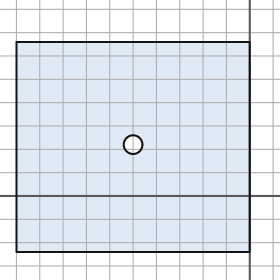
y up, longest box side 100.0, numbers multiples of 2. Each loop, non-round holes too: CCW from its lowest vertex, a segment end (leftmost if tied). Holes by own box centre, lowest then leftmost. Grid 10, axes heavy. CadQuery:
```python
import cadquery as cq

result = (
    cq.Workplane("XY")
    .moveTo(-100.0, -24.0)
    .lineTo(0.0, -24.0)
    .lineTo(0.0, 66.0)
    .lineTo(-100.0, 66.0)
    .close()
    .moveTo(-50.0, 22.0)
    .circle(4.0)
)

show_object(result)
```